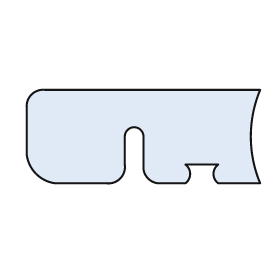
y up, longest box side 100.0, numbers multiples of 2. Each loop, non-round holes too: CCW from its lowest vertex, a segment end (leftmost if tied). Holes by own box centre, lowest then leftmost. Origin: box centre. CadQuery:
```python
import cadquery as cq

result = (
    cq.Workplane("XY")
    .moveTo(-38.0, -20.0)
    .lineTo(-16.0, -20.0)
    .threePointArc((-10.0, -18.0), (-8.0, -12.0))
    .lineTo(-8.0, 0.0)
    .threePointArc((-4.0, 4.0), (0.0, 0.0))
    .lineTo(0.0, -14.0)
    .threePointArc((2.0, -18.0), (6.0, -20.0))
    .lineTo(18.0, -20.0)
    .threePointArc((20.0, -16.0), (18.0, -12.0))
    .lineTo(32.0, -12.0)
    .threePointArc((30.0, -16.0), (32.0, -20.0))
    .lineTo(50.0, -20.0)
    .threePointArc((46.0, 0.0), (50.0, 20.0))
    .lineTo(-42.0, 20.0)
    .threePointArc((-48.0, 18.0), (-50.0, 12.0))
    .lineTo(-50.0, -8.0)
    .threePointArc((-46.0, -16.0), (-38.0, -20.0))
    .close()
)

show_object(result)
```